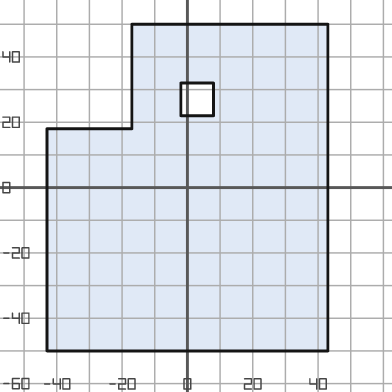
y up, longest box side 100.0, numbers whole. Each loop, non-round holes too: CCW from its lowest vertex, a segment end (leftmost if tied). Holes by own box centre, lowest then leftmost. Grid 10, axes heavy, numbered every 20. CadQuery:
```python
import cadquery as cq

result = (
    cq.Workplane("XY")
    .moveTo(-43.0, -50.0)
    .lineTo(43.0, -50.0)
    .lineTo(43.0, 50.0)
    .lineTo(-17.0, 50.0)
    .lineTo(-17.0, 18.0)
    .lineTo(-43.0, 18.0)
    .close()
    .moveTo(-2.0, 22.0)
    .lineTo(8.0, 22.0)
    .lineTo(8.0, 32.0)
    .lineTo(-2.0, 32.0)
    .close()
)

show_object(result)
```